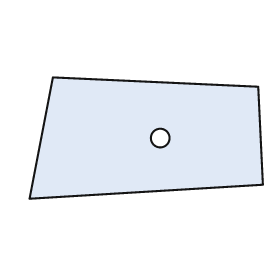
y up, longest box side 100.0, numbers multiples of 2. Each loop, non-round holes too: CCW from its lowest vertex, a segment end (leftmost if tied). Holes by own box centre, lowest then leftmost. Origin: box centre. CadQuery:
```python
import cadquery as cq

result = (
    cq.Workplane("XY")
    .moveTo(-50.0, -26.0)
    .lineTo(50.0, -20.0)
    .lineTo(48.0, 22.0)
    .lineTo(-40.0, 26.0)
    .close()
    .moveTo(6.0, 0.0)
    .circle(4.0)
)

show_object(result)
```